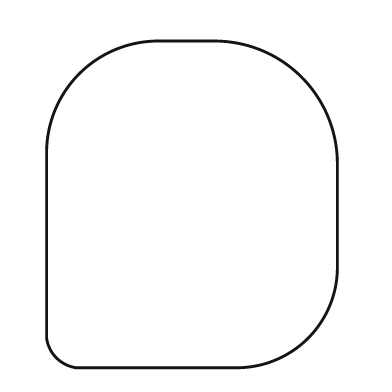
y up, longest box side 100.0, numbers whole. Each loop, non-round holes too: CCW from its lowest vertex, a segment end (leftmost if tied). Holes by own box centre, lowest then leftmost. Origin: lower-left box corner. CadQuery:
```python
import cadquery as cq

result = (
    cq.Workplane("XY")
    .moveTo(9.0, 0.0)
    .lineTo(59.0, 0.0)
    .threePointArc((80.0, 9.0), (89.0, 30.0))
    .lineTo(89.0, 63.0)
    .threePointArc((78.0, 89.0), (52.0, 100.0))
    .lineTo(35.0, 100.0)
    .threePointArc((10.0, 90.0), (0.0, 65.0))
    .lineTo(0.0, 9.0)
    .threePointArc((3.0, 3.0), (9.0, 0.0))
    .close()
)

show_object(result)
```